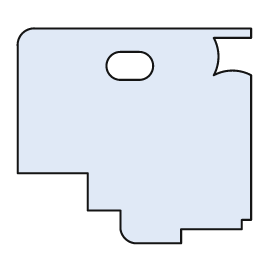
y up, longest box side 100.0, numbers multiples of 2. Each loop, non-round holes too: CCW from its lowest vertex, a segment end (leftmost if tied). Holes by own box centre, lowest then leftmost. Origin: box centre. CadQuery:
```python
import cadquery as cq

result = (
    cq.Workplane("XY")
    .moveTo(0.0, -46.0)
    .lineTo(20.0, -46.0)
    .lineTo(20.0, -40.0)
    .lineTo(46.0, -40.0)
    .lineTo(46.0, -36.0)
    .lineTo(50.0, -36.0)
    .lineTo(50.0, 26.0)
    .threePointArc((42.0, 28.0), (34.0, 26.0))
    .threePointArc((36.0, 34.0), (34.0, 42.0))
    .lineTo(50.0, 42.0)
    .lineTo(50.0, 46.0)
    .lineTo(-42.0, 46.0)
    .threePointArc((-48.0, 44.0), (-50.0, 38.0))
    .lineTo(-50.0, -16.0)
    .lineTo(-20.0, -16.0)
    .lineTo(-20.0, -32.0)
    .lineTo(-6.0, -32.0)
    .lineTo(-6.0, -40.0)
    .threePointArc((-4.0, -44.0), (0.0, -46.0))
    .close()
    .moveTo(-6.0, 24.0)
    .lineTo(2.0, 24.0)
    .threePointArc((8.0, 30.0), (2.0, 36.0))
    .lineTo(-6.0, 36.0)
    .threePointArc((-12.0, 30.0), (-6.0, 24.0))
    .close()
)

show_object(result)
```